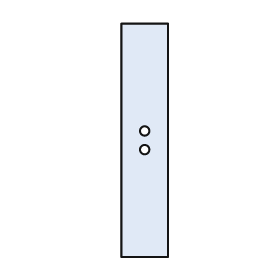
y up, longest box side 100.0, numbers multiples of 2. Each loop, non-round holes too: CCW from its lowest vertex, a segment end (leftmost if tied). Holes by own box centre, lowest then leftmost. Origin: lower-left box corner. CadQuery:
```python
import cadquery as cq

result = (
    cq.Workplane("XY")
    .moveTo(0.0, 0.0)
    .lineTo(20.0, 0.0)
    .lineTo(20.0, 100.0)
    .lineTo(0.0, 100.0)
    .close()
    .moveTo(10.0, 46.0)
    .circle(2.0)
    .moveTo(10.0, 54.0)
    .circle(2.0)
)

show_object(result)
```